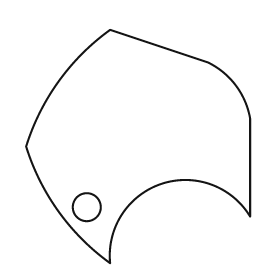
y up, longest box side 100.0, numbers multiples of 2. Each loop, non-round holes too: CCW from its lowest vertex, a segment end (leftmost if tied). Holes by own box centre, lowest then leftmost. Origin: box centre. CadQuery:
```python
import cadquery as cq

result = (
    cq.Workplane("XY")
    .moveTo(-12.0, -50.0)
    .threePointArc((10.0, -16.0), (48.0, -30.0))
    .lineTo(48.0, 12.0)
    .threePointArc((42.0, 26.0), (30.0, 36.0))
    .lineTo(-12.0, 50.0)
    .threePointArc((-34.0, 28.0), (-48.0, 0.0))
    .threePointArc((-34.0, -28.0), (-12.0, -50.0))
    .close()
    .moveTo(-22.0, -26.0)
    .circle(6.0)
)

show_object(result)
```